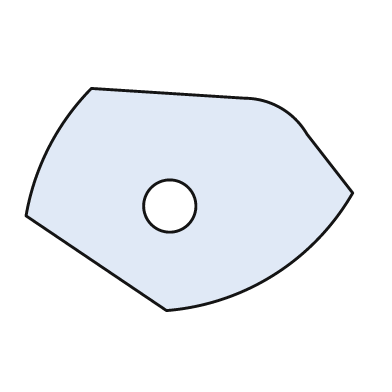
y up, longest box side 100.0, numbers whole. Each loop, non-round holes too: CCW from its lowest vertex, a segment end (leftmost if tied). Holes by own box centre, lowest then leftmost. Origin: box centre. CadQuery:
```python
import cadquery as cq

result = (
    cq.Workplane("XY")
    .moveTo(-7.0, -34.0)
    .threePointArc((26.0, -23.0), (50.0, 2.0))
    .lineTo(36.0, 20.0)
    .threePointArc((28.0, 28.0), (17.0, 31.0))
    .lineTo(-30.0, 34.0)
    .threePointArc((-43.0, 16.0), (-50.0, -5.0))
    .close()
    .moveTo(-6.0, -2.0)
    .circle(8.0)
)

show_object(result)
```